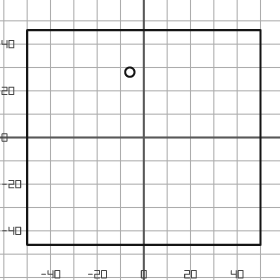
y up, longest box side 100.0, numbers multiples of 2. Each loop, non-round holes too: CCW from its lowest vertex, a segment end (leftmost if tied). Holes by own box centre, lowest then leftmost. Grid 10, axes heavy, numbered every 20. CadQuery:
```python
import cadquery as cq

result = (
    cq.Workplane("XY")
    .moveTo(-50.0, -46.0)
    .lineTo(50.0, -46.0)
    .lineTo(50.0, 46.0)
    .lineTo(-50.0, 46.0)
    .close()
    .moveTo(-6.0, 28.0)
    .circle(2.0)
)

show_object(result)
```